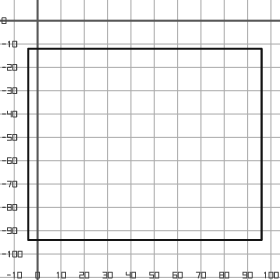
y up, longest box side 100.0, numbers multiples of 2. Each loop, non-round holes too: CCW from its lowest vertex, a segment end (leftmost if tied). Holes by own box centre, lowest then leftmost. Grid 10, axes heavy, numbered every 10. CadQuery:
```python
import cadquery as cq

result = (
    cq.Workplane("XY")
    .moveTo(-4.0, -94.0)
    .lineTo(96.0, -94.0)
    .lineTo(96.0, -12.0)
    .lineTo(-4.0, -12.0)
    .close()
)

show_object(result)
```